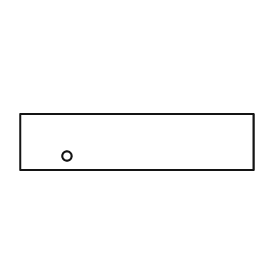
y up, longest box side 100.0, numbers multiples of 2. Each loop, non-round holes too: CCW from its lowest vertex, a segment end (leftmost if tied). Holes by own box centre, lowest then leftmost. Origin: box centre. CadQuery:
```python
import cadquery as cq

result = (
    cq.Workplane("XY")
    .moveTo(-50.0, -12.0)
    .lineTo(50.0, -12.0)
    .lineTo(50.0, 12.0)
    .lineTo(-50.0, 12.0)
    .close()
    .moveTo(-30.0, -6.0)
    .circle(2.0)
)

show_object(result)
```